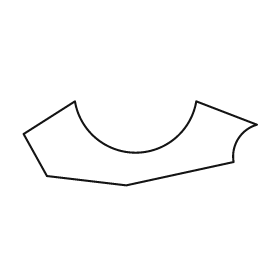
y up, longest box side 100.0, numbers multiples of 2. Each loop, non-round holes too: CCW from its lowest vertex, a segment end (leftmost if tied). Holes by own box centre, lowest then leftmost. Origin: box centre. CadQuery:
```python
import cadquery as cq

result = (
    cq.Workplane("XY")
    .moveTo(-6.0, -18.0)
    .lineTo(40.0, -8.0)
    .threePointArc((42.0, 2.0), (50.0, 8.0))
    .lineTo(24.0, 18.0)
    .threePointArc((-2.0, -4.0), (-28.0, 18.0))
    .lineTo(-50.0, 4.0)
    .lineTo(-40.0, -14.0)
    .close()
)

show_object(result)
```